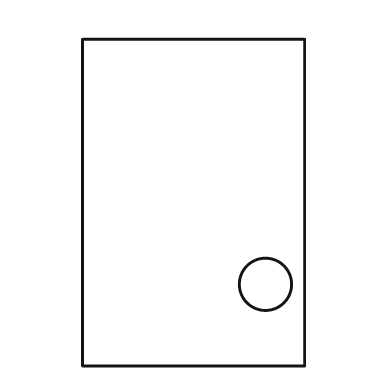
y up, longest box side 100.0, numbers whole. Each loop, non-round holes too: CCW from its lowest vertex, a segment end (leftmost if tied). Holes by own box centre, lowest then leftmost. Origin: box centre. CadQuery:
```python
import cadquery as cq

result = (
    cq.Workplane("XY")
    .moveTo(-34.0, -50.0)
    .lineTo(34.0, -50.0)
    .lineTo(34.0, 50.0)
    .lineTo(-34.0, 50.0)
    .close()
    .moveTo(22.0, -25.0)
    .circle(8.0)
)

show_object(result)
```